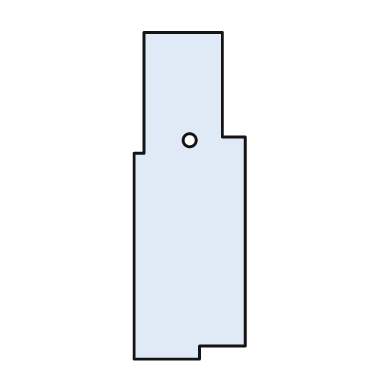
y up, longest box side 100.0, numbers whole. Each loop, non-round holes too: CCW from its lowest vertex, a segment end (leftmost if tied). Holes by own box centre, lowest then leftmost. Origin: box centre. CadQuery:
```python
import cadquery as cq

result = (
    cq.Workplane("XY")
    .moveTo(-17.0, -50.0)
    .lineTo(3.0, -50.0)
    .lineTo(3.0, -46.0)
    .lineTo(17.0, -46.0)
    .lineTo(17.0, 18.0)
    .lineTo(10.0, 18.0)
    .lineTo(10.0, 50.0)
    .lineTo(-14.0, 50.0)
    .lineTo(-14.0, 13.0)
    .lineTo(-17.0, 13.0)
    .close()
    .moveTo(0.0, 17.0)
    .circle(2.0)
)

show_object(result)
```